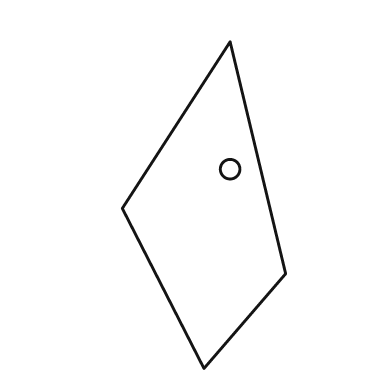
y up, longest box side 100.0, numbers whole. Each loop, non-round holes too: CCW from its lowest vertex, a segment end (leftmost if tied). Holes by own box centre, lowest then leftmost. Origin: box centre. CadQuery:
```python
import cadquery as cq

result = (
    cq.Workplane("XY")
    .moveTo(0.0, -50.0)
    .lineTo(25.0, -21.0)
    .lineTo(8.0, 50.0)
    .lineTo(-25.0, -1.0)
    .close()
    .moveTo(8.0, 11.0)
    .circle(3.0)
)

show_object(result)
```